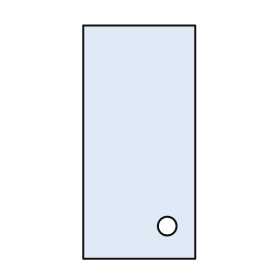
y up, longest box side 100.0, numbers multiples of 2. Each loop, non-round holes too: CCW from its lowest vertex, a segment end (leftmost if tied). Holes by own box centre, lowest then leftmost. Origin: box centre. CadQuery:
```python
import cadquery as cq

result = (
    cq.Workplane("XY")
    .moveTo(-24.0, -50.0)
    .lineTo(24.0, -50.0)
    .lineTo(24.0, 50.0)
    .lineTo(-24.0, 50.0)
    .close()
    .moveTo(12.0, -36.0)
    .circle(4.0)
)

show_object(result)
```